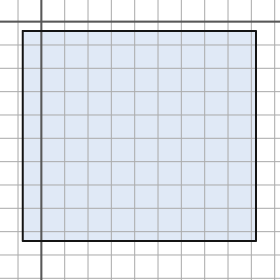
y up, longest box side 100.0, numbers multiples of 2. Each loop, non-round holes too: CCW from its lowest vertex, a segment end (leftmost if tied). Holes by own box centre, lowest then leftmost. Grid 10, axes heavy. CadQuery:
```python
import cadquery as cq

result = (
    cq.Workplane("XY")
    .moveTo(-8.0, -94.0)
    .lineTo(92.0, -94.0)
    .lineTo(92.0, -4.0)
    .lineTo(-8.0, -4.0)
    .close()
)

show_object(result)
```